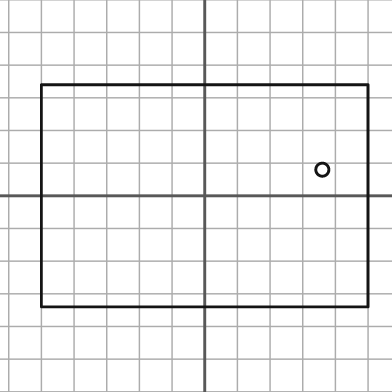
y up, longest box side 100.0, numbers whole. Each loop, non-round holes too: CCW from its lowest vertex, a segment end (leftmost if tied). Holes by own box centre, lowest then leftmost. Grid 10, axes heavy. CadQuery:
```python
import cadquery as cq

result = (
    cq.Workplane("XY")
    .moveTo(-50.0, -34.0)
    .lineTo(50.0, -34.0)
    .lineTo(50.0, 34.0)
    .lineTo(-50.0, 34.0)
    .close()
    .moveTo(36.0, 8.0)
    .circle(2.0)
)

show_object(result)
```